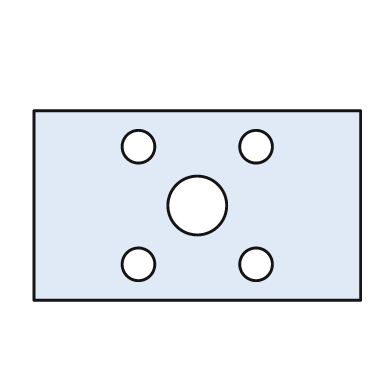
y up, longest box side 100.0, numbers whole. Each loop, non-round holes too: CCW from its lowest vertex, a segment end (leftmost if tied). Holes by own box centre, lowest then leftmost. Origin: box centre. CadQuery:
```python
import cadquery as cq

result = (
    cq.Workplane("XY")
    .moveTo(-50.0, -29.0)
    .lineTo(50.0, -29.0)
    .lineTo(50.0, 29.0)
    .lineTo(-50.0, 29.0)
    .close()
    .moveTo(-18.0, -18.0)
    .circle(5.0)
    .moveTo(18.0, -18.0)
    .circle(5.0)
    .moveTo(0.0, 0.0)
    .circle(9.0)
    .moveTo(-18.0, 18.0)
    .circle(5.0)
    .moveTo(18.0, 18.0)
    .circle(5.0)
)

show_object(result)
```